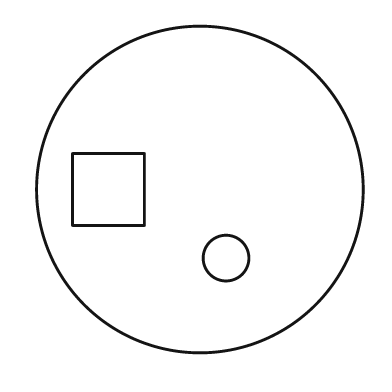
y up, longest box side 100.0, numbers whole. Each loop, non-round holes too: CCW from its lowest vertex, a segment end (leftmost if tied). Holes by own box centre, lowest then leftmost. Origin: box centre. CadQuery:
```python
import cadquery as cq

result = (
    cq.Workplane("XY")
    .moveTo(0.0, 0.0)
    .circle(50.0)
    .moveTo(8.0, -21.0)
    .circle(7.0)
    .moveTo(-39.0, -11.0)
    .lineTo(-17.0, -11.0)
    .lineTo(-17.0, 11.0)
    .lineTo(-39.0, 11.0)
    .close()
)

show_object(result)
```